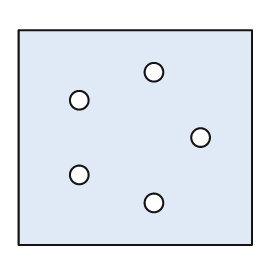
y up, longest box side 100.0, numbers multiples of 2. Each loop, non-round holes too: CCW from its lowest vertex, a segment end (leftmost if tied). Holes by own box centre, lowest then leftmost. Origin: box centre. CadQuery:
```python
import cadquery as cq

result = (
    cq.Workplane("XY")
    .moveTo(-50.0, -46.0)
    .lineTo(50.0, -46.0)
    .lineTo(50.0, 46.0)
    .lineTo(-50.0, 46.0)
    .close()
    .moveTo(8.0, -28.0)
    .circle(4.0)
    .moveTo(-24.0, -16.0)
    .circle(4.0)
    .moveTo(28.0, 0.0)
    .circle(4.0)
    .moveTo(-24.0, 16.0)
    .circle(4.0)
    .moveTo(8.0, 28.0)
    .circle(4.0)
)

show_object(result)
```